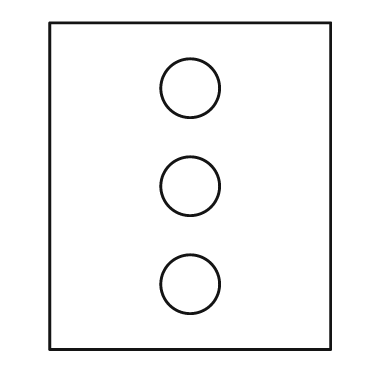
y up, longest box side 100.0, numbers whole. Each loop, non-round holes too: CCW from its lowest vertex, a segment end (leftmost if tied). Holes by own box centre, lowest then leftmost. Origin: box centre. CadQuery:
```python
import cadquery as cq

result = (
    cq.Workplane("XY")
    .moveTo(-43.0, -50.0)
    .lineTo(43.0, -50.0)
    .lineTo(43.0, 50.0)
    .lineTo(-43.0, 50.0)
    .close()
    .moveTo(0.0, -30.0)
    .circle(9.0)
    .moveTo(0.0, 0.0)
    .circle(9.0)
    .moveTo(0.0, 30.0)
    .circle(9.0)
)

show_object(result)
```